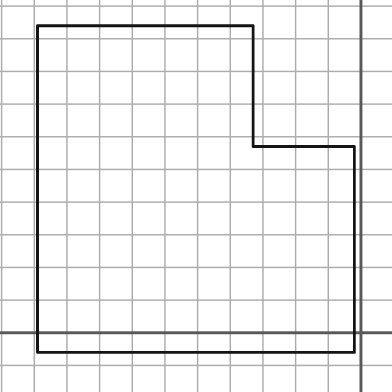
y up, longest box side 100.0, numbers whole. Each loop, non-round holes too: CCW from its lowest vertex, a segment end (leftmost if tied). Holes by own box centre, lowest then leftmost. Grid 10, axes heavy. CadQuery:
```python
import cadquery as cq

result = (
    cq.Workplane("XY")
    .moveTo(-99.0, -6.0)
    .lineTo(-2.0, -6.0)
    .lineTo(-2.0, 57.0)
    .lineTo(-33.0, 57.0)
    .lineTo(-33.0, 94.0)
    .lineTo(-99.0, 94.0)
    .close()
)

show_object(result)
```